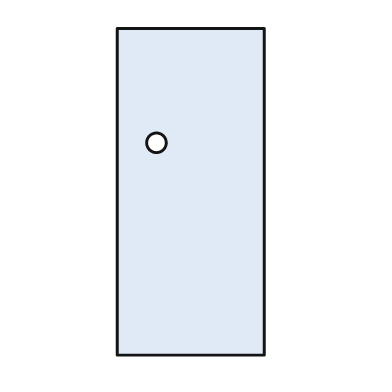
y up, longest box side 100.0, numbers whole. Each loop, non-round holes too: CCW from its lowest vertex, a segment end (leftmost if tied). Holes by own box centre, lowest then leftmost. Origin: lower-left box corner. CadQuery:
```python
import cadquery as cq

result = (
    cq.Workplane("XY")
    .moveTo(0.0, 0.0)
    .lineTo(45.0, 0.0)
    .lineTo(45.0, 100.0)
    .lineTo(0.0, 100.0)
    .close()
    .moveTo(12.0, 65.0)
    .circle(3.0)
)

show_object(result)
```